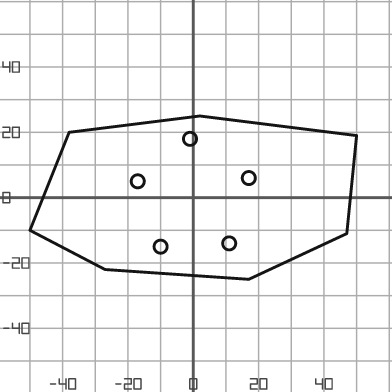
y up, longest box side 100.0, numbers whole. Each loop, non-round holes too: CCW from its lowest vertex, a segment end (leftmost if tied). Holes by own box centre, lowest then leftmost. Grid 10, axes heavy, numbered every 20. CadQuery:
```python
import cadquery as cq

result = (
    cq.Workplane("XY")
    .moveTo(17.0, -25.0)
    .lineTo(47.0, -11.0)
    .lineTo(50.0, 19.0)
    .lineTo(2.0, 25.0)
    .lineTo(-38.0, 20.0)
    .lineTo(-50.0, -10.0)
    .lineTo(-27.0, -22.0)
    .close()
    .moveTo(-10.0, -15.0)
    .circle(2.0)
    .moveTo(11.0, -14.0)
    .circle(2.0)
    .moveTo(-17.0, 5.0)
    .circle(2.0)
    .moveTo(17.0, 6.0)
    .circle(2.0)
    .moveTo(-1.0, 18.0)
    .circle(2.0)
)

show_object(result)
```